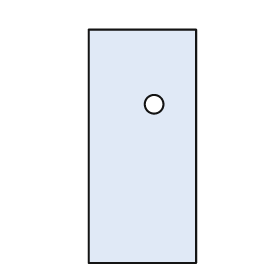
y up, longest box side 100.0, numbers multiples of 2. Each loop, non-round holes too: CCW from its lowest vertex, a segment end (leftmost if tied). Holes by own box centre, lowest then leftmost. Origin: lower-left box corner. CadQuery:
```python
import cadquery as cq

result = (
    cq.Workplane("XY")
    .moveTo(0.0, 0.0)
    .lineTo(46.0, 0.0)
    .lineTo(46.0, 100.0)
    .lineTo(0.0, 100.0)
    .close()
    .moveTo(28.0, 68.0)
    .circle(4.0)
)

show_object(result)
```